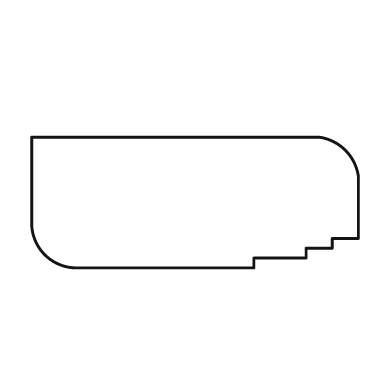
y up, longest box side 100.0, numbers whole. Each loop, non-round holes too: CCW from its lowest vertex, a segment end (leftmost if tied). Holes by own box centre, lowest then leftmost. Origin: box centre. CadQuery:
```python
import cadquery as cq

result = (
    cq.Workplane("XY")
    .moveTo(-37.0, -20.0)
    .lineTo(18.0, -20.0)
    .lineTo(18.0, -17.0)
    .lineTo(34.0, -17.0)
    .lineTo(34.0, -14.0)
    .lineTo(42.0, -14.0)
    .lineTo(42.0, -11.0)
    .lineTo(50.0, -11.0)
    .lineTo(50.0, 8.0)
    .threePointArc((46.0, 16.0), (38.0, 20.0))
    .lineTo(-50.0, 20.0)
    .lineTo(-50.0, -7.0)
    .threePointArc((-46.0, -16.0), (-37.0, -20.0))
    .close()
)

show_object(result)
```